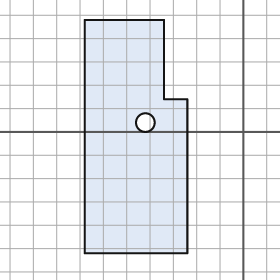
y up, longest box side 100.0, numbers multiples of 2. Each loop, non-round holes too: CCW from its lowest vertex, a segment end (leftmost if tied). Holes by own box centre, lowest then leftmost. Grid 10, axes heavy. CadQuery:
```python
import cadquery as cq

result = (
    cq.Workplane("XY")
    .moveTo(-68.0, -52.0)
    .lineTo(-24.0, -52.0)
    .lineTo(-24.0, 14.0)
    .lineTo(-34.0, 14.0)
    .lineTo(-34.0, 48.0)
    .lineTo(-68.0, 48.0)
    .close()
    .moveTo(-42.0, 4.0)
    .circle(4.0)
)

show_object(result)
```